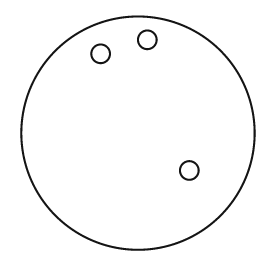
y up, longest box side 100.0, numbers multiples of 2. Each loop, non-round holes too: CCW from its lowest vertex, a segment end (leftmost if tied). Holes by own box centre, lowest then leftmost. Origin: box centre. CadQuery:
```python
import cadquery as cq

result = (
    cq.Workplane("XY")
    .moveTo(0.0, 0.0)
    .circle(50.0)
    .moveTo(22.0, -16.0)
    .circle(4.0)
    .moveTo(-16.0, 34.0)
    .circle(4.0)
    .moveTo(4.0, 40.0)
    .circle(4.0)
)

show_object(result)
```